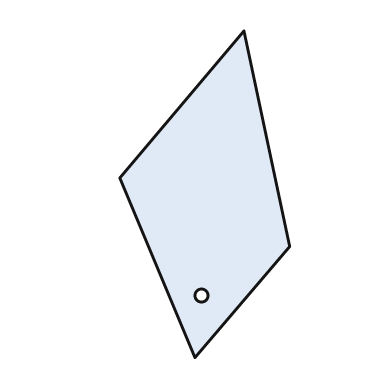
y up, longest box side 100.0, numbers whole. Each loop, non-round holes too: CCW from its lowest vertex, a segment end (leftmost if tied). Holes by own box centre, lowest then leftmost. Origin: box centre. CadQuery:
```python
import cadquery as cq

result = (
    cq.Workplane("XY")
    .moveTo(-3.0, -50.0)
    .lineTo(26.0, -16.0)
    .lineTo(12.0, 50.0)
    .lineTo(-26.0, 5.0)
    .close()
    .moveTo(-1.0, -31.0)
    .circle(2.0)
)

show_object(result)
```